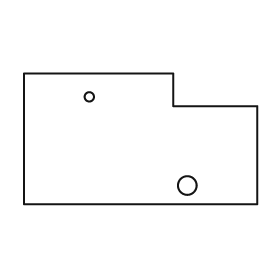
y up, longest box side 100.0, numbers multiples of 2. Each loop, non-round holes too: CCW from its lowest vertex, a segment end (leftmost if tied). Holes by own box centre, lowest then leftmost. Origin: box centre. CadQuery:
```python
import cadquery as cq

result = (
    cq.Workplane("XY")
    .moveTo(-50.0, -28.0)
    .lineTo(50.0, -28.0)
    .lineTo(50.0, 14.0)
    .lineTo(14.0, 14.0)
    .lineTo(14.0, 28.0)
    .lineTo(-50.0, 28.0)
    .close()
    .moveTo(20.0, -20.0)
    .circle(4.0)
    .moveTo(-22.0, 18.0)
    .circle(2.0)
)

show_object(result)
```